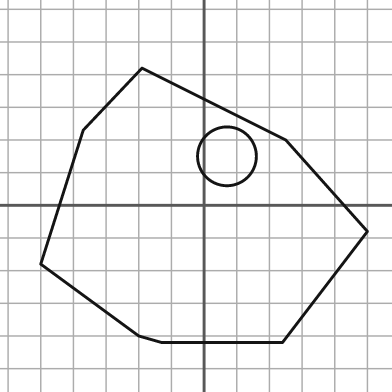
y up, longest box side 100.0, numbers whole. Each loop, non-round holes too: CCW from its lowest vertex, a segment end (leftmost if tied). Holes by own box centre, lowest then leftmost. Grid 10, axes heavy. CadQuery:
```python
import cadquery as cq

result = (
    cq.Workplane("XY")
    .moveTo(-13.0, -42.0)
    .lineTo(24.0, -42.0)
    .lineTo(50.0, -8.0)
    .lineTo(25.0, 20.0)
    .lineTo(-19.0, 42.0)
    .lineTo(-37.0, 23.0)
    .lineTo(-50.0, -18.0)
    .lineTo(-20.0, -40.0)
    .close()
    .moveTo(7.0, 15.0)
    .circle(9.0)
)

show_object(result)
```